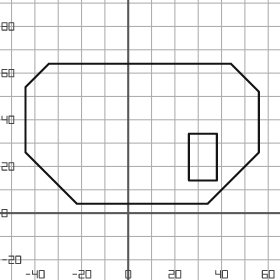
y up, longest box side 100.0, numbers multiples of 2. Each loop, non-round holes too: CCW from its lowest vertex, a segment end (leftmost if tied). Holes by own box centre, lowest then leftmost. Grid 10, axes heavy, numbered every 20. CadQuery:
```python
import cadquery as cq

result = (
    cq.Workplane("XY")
    .moveTo(-22.0, 4.0)
    .lineTo(34.0, 4.0)
    .lineTo(56.0, 26.0)
    .lineTo(56.0, 52.0)
    .lineTo(44.0, 64.0)
    .lineTo(-34.0, 64.0)
    .lineTo(-44.0, 54.0)
    .lineTo(-44.0, 26.0)
    .close()
    .moveTo(26.0, 14.0)
    .lineTo(38.0, 14.0)
    .lineTo(38.0, 34.0)
    .lineTo(26.0, 34.0)
    .close()
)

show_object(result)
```